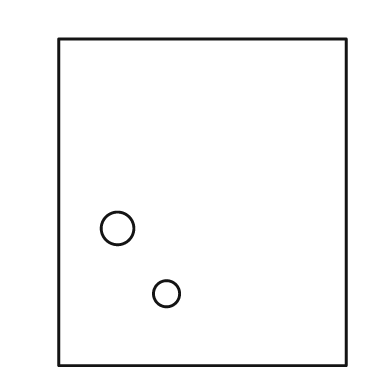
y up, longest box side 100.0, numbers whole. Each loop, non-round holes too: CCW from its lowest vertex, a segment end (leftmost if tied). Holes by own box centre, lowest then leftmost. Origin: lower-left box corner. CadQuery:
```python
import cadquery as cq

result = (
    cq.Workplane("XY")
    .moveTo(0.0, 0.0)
    .lineTo(88.0, 0.0)
    .lineTo(88.0, 100.0)
    .lineTo(0.0, 100.0)
    .close()
    .moveTo(33.0, 22.0)
    .circle(4.0)
    .moveTo(18.0, 42.0)
    .circle(5.0)
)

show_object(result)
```